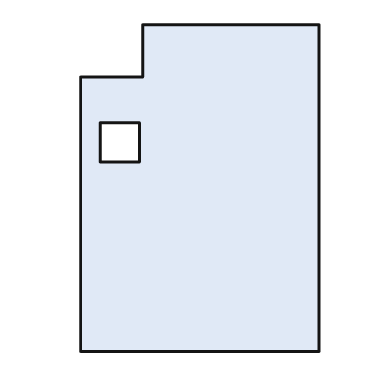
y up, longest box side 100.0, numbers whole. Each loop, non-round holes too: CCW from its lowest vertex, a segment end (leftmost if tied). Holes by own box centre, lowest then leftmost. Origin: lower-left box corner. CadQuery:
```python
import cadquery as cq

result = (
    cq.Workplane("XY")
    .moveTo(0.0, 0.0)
    .lineTo(73.0, 0.0)
    .lineTo(73.0, 100.0)
    .lineTo(19.0, 100.0)
    .lineTo(19.0, 84.0)
    .lineTo(0.0, 84.0)
    .close()
    .moveTo(6.0, 58.0)
    .lineTo(18.0, 58.0)
    .lineTo(18.0, 70.0)
    .lineTo(6.0, 70.0)
    .close()
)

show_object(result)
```